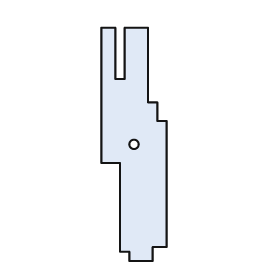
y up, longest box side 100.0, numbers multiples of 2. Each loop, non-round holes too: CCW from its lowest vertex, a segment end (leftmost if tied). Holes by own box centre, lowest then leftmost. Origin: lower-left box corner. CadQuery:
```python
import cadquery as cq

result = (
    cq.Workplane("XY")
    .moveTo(12.0, 0.0)
    .lineTo(22.0, 0.0)
    .lineTo(22.0, 6.0)
    .lineTo(28.0, 6.0)
    .lineTo(28.0, 60.0)
    .lineTo(24.0, 60.0)
    .lineTo(24.0, 68.0)
    .lineTo(20.0, 68.0)
    .lineTo(20.0, 100.0)
    .lineTo(10.0, 100.0)
    .lineTo(10.0, 78.0)
    .lineTo(6.0, 78.0)
    .lineTo(6.0, 100.0)
    .lineTo(0.0, 100.0)
    .lineTo(0.0, 42.0)
    .lineTo(8.0, 42.0)
    .lineTo(8.0, 4.0)
    .lineTo(12.0, 4.0)
    .close()
    .moveTo(14.0, 50.0)
    .circle(2.0)
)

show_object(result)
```